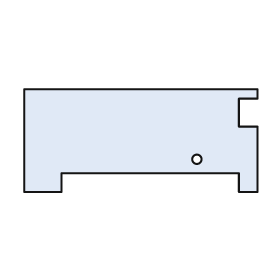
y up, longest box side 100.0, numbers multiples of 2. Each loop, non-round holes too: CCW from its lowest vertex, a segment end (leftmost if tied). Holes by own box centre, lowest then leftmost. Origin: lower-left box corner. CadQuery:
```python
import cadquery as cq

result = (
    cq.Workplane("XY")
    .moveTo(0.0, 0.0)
    .lineTo(16.0, 0.0)
    .lineTo(16.0, 8.0)
    .lineTo(92.0, 8.0)
    .lineTo(92.0, 0.0)
    .lineTo(100.0, 0.0)
    .lineTo(100.0, 28.0)
    .lineTo(92.0, 28.0)
    .lineTo(92.0, 40.0)
    .lineTo(100.0, 40.0)
    .lineTo(100.0, 44.0)
    .lineTo(0.0, 44.0)
    .close()
    .moveTo(74.0, 14.0)
    .circle(2.0)
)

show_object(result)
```